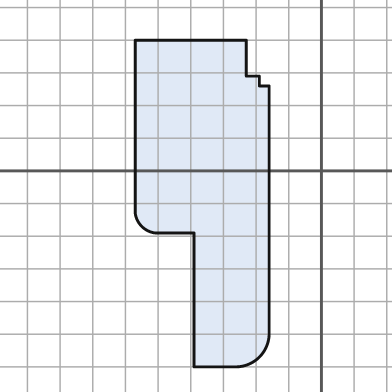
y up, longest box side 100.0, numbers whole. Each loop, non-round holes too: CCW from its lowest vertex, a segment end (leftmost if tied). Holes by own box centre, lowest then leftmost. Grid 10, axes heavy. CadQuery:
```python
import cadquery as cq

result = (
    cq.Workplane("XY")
    .moveTo(-39.0, -60.0)
    .lineTo(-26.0, -60.0)
    .threePointArc((-19.0, -57.0), (-16.0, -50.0))
    .lineTo(-16.0, 26.0)
    .lineTo(-19.0, 26.0)
    .lineTo(-19.0, 29.0)
    .lineTo(-23.0, 29.0)
    .lineTo(-23.0, 40.0)
    .lineTo(-57.0, 40.0)
    .lineTo(-57.0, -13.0)
    .threePointArc((-55.0, -17.0), (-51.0, -19.0))
    .lineTo(-39.0, -19.0)
    .close()
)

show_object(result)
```